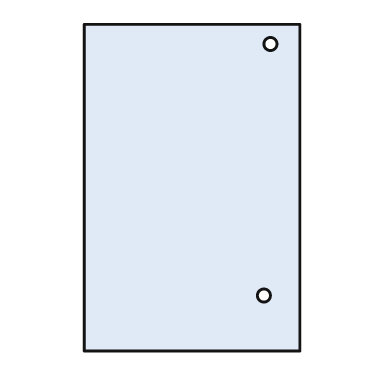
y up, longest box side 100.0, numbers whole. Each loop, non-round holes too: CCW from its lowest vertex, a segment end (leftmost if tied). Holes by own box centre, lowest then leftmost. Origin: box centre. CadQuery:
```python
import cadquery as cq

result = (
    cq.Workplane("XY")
    .moveTo(-33.0, -50.0)
    .lineTo(33.0, -50.0)
    .lineTo(33.0, 50.0)
    .lineTo(-33.0, 50.0)
    .close()
    .moveTo(22.0, -33.0)
    .circle(2.0)
    .moveTo(24.0, 44.0)
    .circle(2.0)
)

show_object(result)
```